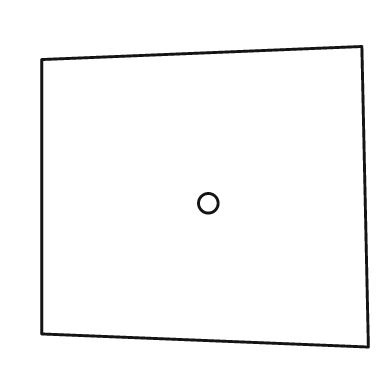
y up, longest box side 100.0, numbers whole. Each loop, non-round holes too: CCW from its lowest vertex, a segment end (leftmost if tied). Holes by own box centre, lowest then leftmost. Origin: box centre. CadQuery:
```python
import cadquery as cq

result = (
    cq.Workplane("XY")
    .moveTo(50.0, -46.0)
    .lineTo(48.0, 46.0)
    .lineTo(-50.0, 42.0)
    .lineTo(-50.0, -42.0)
    .close()
    .moveTo(1.0, -2.0)
    .circle(3.0)
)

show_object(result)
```